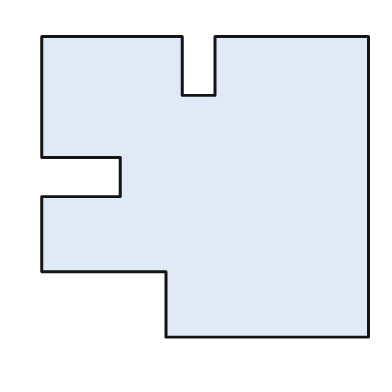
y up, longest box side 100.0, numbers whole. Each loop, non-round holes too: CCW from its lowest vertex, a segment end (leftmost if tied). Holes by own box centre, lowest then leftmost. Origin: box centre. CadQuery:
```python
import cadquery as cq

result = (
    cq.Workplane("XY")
    .moveTo(-12.0, -46.0)
    .lineTo(50.0, -46.0)
    .lineTo(50.0, 46.0)
    .lineTo(3.0, 46.0)
    .lineTo(3.0, 28.0)
    .lineTo(-7.0, 28.0)
    .lineTo(-7.0, 46.0)
    .lineTo(-50.0, 46.0)
    .lineTo(-50.0, 9.0)
    .lineTo(-26.0, 9.0)
    .lineTo(-26.0, -3.0)
    .lineTo(-50.0, -3.0)
    .lineTo(-50.0, -26.0)
    .lineTo(-12.0, -26.0)
    .close()
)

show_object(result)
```